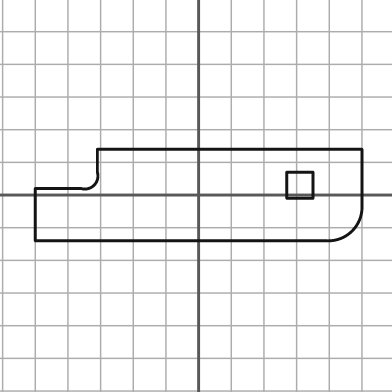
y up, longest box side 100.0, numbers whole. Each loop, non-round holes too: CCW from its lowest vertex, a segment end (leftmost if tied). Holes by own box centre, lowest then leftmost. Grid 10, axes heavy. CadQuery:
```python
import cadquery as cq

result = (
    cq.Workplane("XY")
    .moveTo(-50.0, -14.0)
    .lineTo(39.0, -14.0)
    .threePointArc((47.0, -11.0), (50.0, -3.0))
    .lineTo(50.0, 14.0)
    .lineTo(-31.0, 14.0)
    .lineTo(-31.0, 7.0)
    .threePointArc((-32.0, 3.0), (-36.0, 2.0))
    .lineTo(-50.0, 2.0)
    .close()
    .moveTo(27.0, -1.0)
    .lineTo(35.0, -1.0)
    .lineTo(35.0, 7.0)
    .lineTo(27.0, 7.0)
    .close()
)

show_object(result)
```